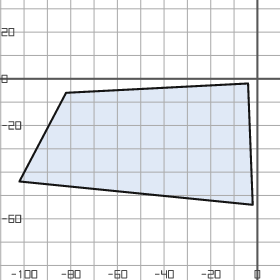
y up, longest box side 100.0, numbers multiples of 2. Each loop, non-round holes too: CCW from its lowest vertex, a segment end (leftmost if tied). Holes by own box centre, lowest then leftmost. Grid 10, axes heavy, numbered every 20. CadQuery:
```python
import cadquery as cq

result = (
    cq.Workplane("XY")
    .moveTo(-2.0, -54.0)
    .lineTo(-4.0, -2.0)
    .lineTo(-82.0, -6.0)
    .lineTo(-102.0, -44.0)
    .close()
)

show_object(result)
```